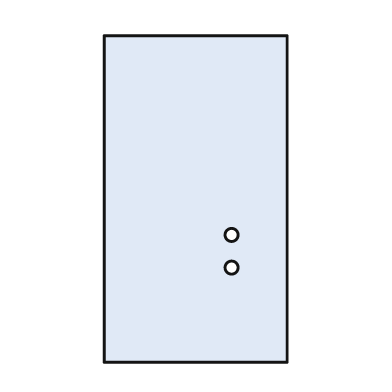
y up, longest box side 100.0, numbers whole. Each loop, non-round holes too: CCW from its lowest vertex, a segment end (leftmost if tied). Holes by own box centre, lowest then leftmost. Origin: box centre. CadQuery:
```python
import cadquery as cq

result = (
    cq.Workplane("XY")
    .moveTo(-28.0, -50.0)
    .lineTo(28.0, -50.0)
    .lineTo(28.0, 50.0)
    .lineTo(-28.0, 50.0)
    .close()
    .moveTo(11.0, -21.0)
    .circle(2.0)
    .moveTo(11.0, -11.0)
    .circle(2.0)
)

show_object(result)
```